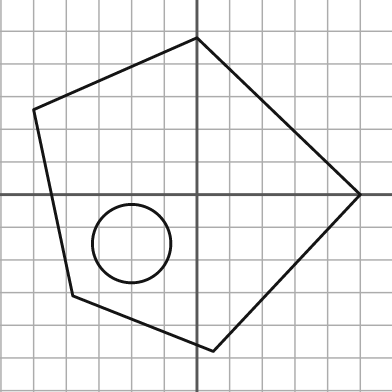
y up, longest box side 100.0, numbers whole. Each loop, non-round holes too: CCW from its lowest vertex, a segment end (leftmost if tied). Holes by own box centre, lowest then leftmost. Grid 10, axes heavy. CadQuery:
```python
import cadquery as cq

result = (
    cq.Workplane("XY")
    .moveTo(5.0, -48.0)
    .lineTo(50.0, 0.0)
    .lineTo(0.0, 48.0)
    .lineTo(-50.0, 26.0)
    .lineTo(-38.0, -31.0)
    .close()
    .moveTo(-20.0, -15.0)
    .circle(12.0)
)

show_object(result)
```